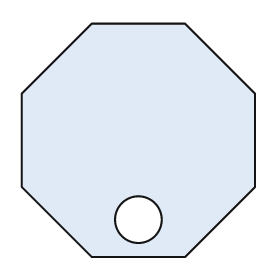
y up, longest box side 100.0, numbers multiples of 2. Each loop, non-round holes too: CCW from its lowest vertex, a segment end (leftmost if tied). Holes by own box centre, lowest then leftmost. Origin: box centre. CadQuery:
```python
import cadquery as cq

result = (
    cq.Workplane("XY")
    .moveTo(-20.0, -50.0)
    .lineTo(20.0, -50.0)
    .lineTo(50.0, -20.0)
    .lineTo(50.0, 20.0)
    .lineTo(20.0, 50.0)
    .lineTo(-20.0, 50.0)
    .lineTo(-50.0, 20.0)
    .lineTo(-50.0, -20.0)
    .close()
    .moveTo(0.0, -34.0)
    .circle(10.0)
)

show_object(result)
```